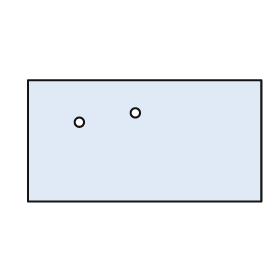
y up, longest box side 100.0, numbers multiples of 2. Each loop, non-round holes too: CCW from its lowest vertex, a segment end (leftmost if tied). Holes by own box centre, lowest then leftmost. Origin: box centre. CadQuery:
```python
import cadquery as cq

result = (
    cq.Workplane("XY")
    .moveTo(-50.0, -26.0)
    .lineTo(50.0, -26.0)
    .lineTo(50.0, 26.0)
    .lineTo(-50.0, 26.0)
    .close()
    .moveTo(-28.0, 8.0)
    .circle(2.0)
    .moveTo(-4.0, 12.0)
    .circle(2.0)
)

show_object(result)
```